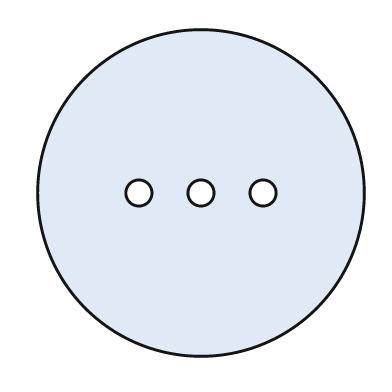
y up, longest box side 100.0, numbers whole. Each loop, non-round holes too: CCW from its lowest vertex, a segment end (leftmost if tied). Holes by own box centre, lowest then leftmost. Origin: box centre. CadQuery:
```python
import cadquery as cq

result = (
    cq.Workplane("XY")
    .moveTo(0.0, 0.0)
    .circle(50.0)
    .moveTo(-19.0, 0.0)
    .circle(4.0)
    .moveTo(0.0, 0.0)
    .circle(4.0)
    .moveTo(19.0, 0.0)
    .circle(4.0)
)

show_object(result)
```